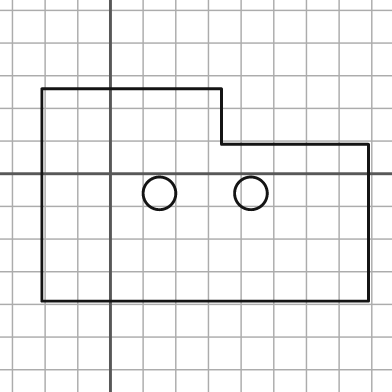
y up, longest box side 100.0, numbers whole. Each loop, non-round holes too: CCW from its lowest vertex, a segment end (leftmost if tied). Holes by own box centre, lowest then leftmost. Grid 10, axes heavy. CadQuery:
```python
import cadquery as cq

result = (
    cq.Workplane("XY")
    .moveTo(-21.0, -39.0)
    .lineTo(79.0, -39.0)
    .lineTo(79.0, 9.0)
    .lineTo(34.0, 9.0)
    .lineTo(34.0, 26.0)
    .lineTo(-21.0, 26.0)
    .close()
    .moveTo(15.0, -6.0)
    .circle(5.0)
    .moveTo(43.0, -6.0)
    .circle(5.0)
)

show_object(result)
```